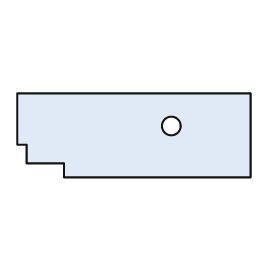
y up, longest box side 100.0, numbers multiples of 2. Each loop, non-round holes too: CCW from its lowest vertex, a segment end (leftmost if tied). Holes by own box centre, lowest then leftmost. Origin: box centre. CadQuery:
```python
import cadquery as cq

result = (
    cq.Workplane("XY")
    .moveTo(-30.0, -18.0)
    .lineTo(50.0, -18.0)
    .lineTo(50.0, 18.0)
    .lineTo(-50.0, 18.0)
    .lineTo(-50.0, -4.0)
    .lineTo(-46.0, -4.0)
    .lineTo(-46.0, -12.0)
    .lineTo(-30.0, -12.0)
    .close()
    .moveTo(16.0, 4.0)
    .circle(4.0)
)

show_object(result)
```